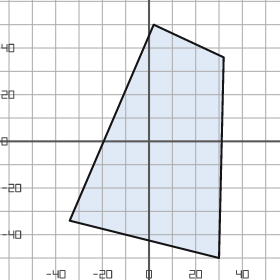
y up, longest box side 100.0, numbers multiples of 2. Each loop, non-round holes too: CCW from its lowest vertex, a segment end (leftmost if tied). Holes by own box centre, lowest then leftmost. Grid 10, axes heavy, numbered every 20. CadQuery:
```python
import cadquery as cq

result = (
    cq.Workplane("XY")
    .moveTo(30.0, -50.0)
    .lineTo(32.0, 36.0)
    .lineTo(2.0, 50.0)
    .lineTo(-34.0, -34.0)
    .close()
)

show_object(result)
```